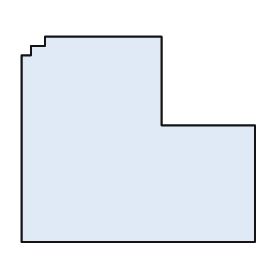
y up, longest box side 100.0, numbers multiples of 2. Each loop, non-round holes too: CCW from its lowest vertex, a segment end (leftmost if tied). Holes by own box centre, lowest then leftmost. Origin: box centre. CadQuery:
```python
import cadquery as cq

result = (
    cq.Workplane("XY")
    .moveTo(-50.0, -44.0)
    .lineTo(50.0, -44.0)
    .lineTo(50.0, 6.0)
    .lineTo(10.0, 6.0)
    .lineTo(10.0, 44.0)
    .lineTo(-40.0, 44.0)
    .lineTo(-40.0, 40.0)
    .lineTo(-46.0, 40.0)
    .lineTo(-46.0, 36.0)
    .lineTo(-50.0, 36.0)
    .close()
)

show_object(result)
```